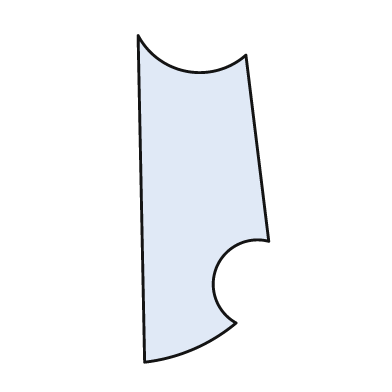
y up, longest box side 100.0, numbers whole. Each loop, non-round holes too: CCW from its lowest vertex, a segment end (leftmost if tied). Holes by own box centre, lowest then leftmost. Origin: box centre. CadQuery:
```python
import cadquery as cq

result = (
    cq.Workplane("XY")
    .moveTo(-18.0, -50.0)
    .threePointArc((-3.0, -46.0), (10.0, -38.0))
    .threePointArc((4.0, -21.0), (20.0, -13.0))
    .lineTo(13.0, 44.0)
    .threePointArc((-5.0, 39.0), (-20.0, 50.0))
    .close()
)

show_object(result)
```